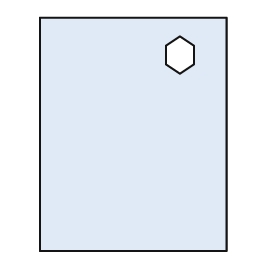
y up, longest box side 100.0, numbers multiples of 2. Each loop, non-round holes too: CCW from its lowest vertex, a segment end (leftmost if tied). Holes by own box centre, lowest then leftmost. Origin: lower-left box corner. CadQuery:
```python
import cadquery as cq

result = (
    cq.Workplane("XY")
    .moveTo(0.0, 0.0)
    .lineTo(80.0, 0.0)
    .lineTo(80.0, 100.0)
    .lineTo(0.0, 100.0)
    .close()
    .moveTo(60.0, 76.0)
    .lineTo(66.0, 80.0)
    .lineTo(66.0, 88.0)
    .lineTo(60.0, 92.0)
    .lineTo(54.0, 88.0)
    .lineTo(54.0, 80.0)
    .close()
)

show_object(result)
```